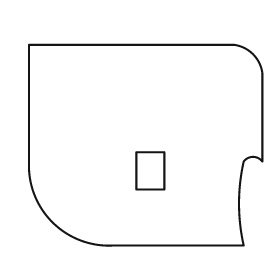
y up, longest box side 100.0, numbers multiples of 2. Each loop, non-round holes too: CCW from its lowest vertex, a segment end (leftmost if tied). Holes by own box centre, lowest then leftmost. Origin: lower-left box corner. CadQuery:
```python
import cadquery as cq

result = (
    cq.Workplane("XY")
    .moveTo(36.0, 0.0)
    .lineTo(92.0, 0.0)
    .threePointArc((90.0, 18.0), (92.0, 36.0))
    .threePointArc((96.0, 38.0), (100.0, 36.0))
    .lineTo(100.0, 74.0)
    .threePointArc((96.0, 82.0), (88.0, 86.0))
    .lineTo(0.0, 86.0)
    .lineTo(0.0, 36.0)
    .threePointArc((10.0, 10.0), (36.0, 0.0))
    .close()
    .moveTo(46.0, 24.0)
    .lineTo(58.0, 24.0)
    .lineTo(58.0, 40.0)
    .lineTo(46.0, 40.0)
    .close()
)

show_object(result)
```